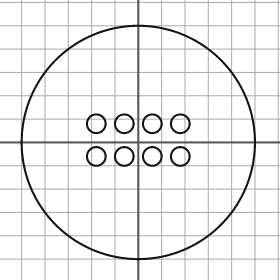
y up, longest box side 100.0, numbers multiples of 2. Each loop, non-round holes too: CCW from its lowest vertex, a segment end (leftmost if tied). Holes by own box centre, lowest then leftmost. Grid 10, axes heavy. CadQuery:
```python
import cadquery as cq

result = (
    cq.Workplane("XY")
    .moveTo(0.0, 0.0)
    .circle(50.0)
    .moveTo(-18.0, -6.0)
    .circle(4.0)
    .moveTo(-6.0, -6.0)
    .circle(4.0)
    .moveTo(6.0, -6.0)
    .circle(4.0)
    .moveTo(18.0, -6.0)
    .circle(4.0)
    .moveTo(-18.0, 8.0)
    .circle(4.0)
    .moveTo(-6.0, 8.0)
    .circle(4.0)
    .moveTo(6.0, 8.0)
    .circle(4.0)
    .moveTo(18.0, 8.0)
    .circle(4.0)
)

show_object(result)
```